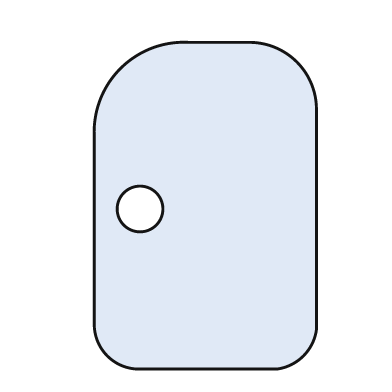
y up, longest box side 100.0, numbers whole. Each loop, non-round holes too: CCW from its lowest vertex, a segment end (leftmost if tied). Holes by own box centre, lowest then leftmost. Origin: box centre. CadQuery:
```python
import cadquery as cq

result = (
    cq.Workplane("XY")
    .moveTo(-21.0, -50.0)
    .lineTo(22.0, -50.0)
    .threePointArc((30.0, -46.0), (34.0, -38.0))
    .lineTo(34.0, 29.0)
    .threePointArc((28.0, 44.0), (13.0, 50.0))
    .lineTo(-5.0, 50.0)
    .threePointArc((-26.0, 42.0), (-34.0, 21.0))
    .lineTo(-34.0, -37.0)
    .threePointArc((-30.0, -46.0), (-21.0, -50.0))
    .close()
    .moveTo(-20.0, -1.0)
    .circle(7.0)
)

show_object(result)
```